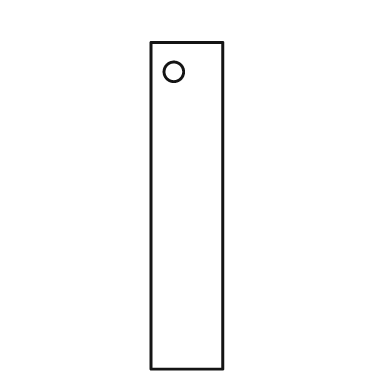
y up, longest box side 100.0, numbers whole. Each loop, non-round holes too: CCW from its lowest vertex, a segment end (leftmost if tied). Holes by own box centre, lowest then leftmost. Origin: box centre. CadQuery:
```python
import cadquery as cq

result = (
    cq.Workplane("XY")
    .moveTo(-11.0, -50.0)
    .lineTo(11.0, -50.0)
    .lineTo(11.0, 50.0)
    .lineTo(-11.0, 50.0)
    .close()
    .moveTo(-4.0, 41.0)
    .circle(3.0)
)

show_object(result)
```